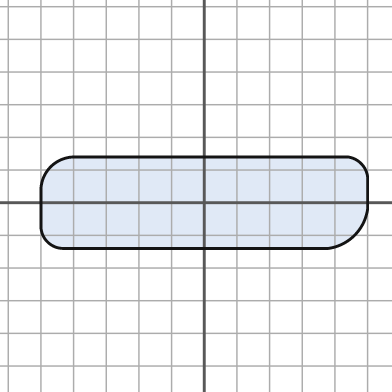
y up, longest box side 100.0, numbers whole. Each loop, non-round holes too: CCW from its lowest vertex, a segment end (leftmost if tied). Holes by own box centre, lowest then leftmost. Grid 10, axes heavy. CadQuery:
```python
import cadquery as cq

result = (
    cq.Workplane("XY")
    .moveTo(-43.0, -14.0)
    .lineTo(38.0, -14.0)
    .threePointArc((46.0, -10.0), (50.0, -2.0))
    .lineTo(50.0, 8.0)
    .threePointArc((48.0, 12.0), (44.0, 14.0))
    .lineTo(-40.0, 14.0)
    .threePointArc((-47.0, 11.0), (-50.0, 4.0))
    .lineTo(-50.0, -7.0)
    .threePointArc((-48.0, -12.0), (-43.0, -14.0))
    .close()
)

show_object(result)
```